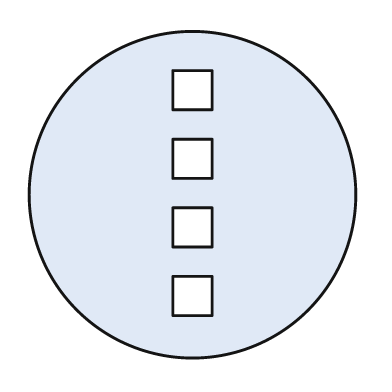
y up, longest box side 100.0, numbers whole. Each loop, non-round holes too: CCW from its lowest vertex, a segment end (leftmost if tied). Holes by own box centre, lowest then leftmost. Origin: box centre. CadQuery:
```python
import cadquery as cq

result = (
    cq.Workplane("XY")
    .moveTo(0.0, 0.0)
    .circle(50.0)
    .moveTo(-6.0, -37.0)
    .lineTo(6.0, -37.0)
    .lineTo(6.0, -25.0)
    .lineTo(-6.0, -25.0)
    .close()
    .moveTo(-6.0, -16.0)
    .lineTo(6.0, -16.0)
    .lineTo(6.0, -4.0)
    .lineTo(-6.0, -4.0)
    .close()
    .moveTo(-6.0, 5.0)
    .lineTo(6.0, 5.0)
    .lineTo(6.0, 17.0)
    .lineTo(-6.0, 17.0)
    .close()
    .moveTo(-6.0, 26.0)
    .lineTo(6.0, 26.0)
    .lineTo(6.0, 38.0)
    .lineTo(-6.0, 38.0)
    .close()
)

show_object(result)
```